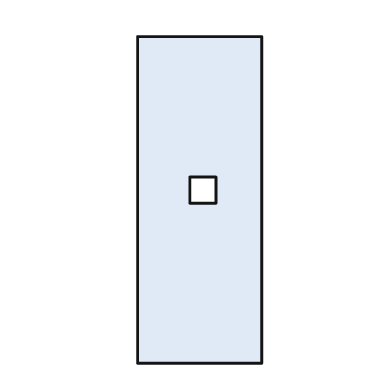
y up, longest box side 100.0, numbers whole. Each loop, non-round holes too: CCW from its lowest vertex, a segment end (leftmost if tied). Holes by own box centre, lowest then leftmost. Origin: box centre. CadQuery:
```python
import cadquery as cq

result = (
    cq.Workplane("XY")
    .moveTo(-19.0, -50.0)
    .lineTo(19.0, -50.0)
    .lineTo(19.0, 50.0)
    .lineTo(-19.0, 50.0)
    .close()
    .moveTo(-3.0, -1.0)
    .lineTo(5.0, -1.0)
    .lineTo(5.0, 7.0)
    .lineTo(-3.0, 7.0)
    .close()
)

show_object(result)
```